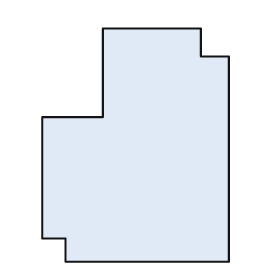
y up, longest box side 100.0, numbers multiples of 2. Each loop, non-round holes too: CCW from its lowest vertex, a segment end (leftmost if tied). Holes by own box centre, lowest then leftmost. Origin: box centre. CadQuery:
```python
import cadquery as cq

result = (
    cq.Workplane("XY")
    .moveTo(-30.0, -50.0)
    .lineTo(40.0, -50.0)
    .lineTo(40.0, 38.0)
    .lineTo(28.0, 38.0)
    .lineTo(28.0, 50.0)
    .lineTo(-14.0, 50.0)
    .lineTo(-14.0, 12.0)
    .lineTo(-40.0, 12.0)
    .lineTo(-40.0, -40.0)
    .lineTo(-30.0, -40.0)
    .close()
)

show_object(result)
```